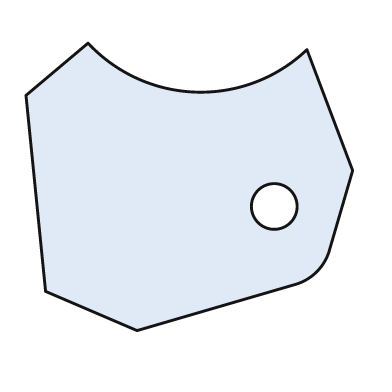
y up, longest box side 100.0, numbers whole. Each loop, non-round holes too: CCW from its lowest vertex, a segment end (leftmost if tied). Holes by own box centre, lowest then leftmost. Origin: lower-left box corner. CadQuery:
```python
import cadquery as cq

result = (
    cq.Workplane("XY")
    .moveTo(34.0, 0.0)
    .lineTo(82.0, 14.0)
    .threePointArc((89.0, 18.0), (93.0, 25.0))
    .lineTo(100.0, 49.0)
    .lineTo(86.0, 86.0)
    .threePointArc((52.0, 73.0), (19.0, 88.0))
    .lineTo(0.0, 72.0)
    .lineTo(6.0, 12.0)
    .close()
    .moveTo(76.0, 38.0)
    .circle(7.0)
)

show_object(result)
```